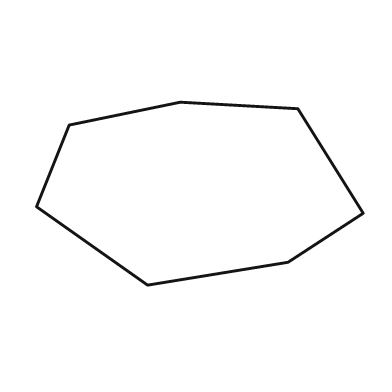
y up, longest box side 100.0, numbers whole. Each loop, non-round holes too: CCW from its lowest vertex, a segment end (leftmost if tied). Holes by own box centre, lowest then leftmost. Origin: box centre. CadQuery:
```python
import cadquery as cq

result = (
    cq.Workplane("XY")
    .moveTo(-16.0, -28.0)
    .lineTo(27.0, -21.0)
    .lineTo(50.0, -6.0)
    .lineTo(30.0, 26.0)
    .lineTo(-6.0, 28.0)
    .lineTo(-40.0, 21.0)
    .lineTo(-50.0, -4.0)
    .close()
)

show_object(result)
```